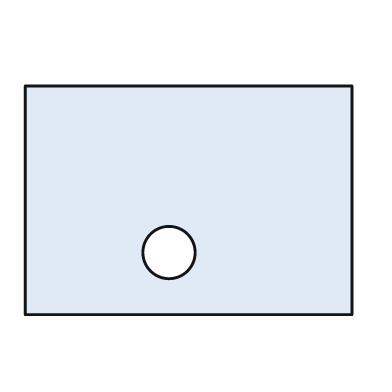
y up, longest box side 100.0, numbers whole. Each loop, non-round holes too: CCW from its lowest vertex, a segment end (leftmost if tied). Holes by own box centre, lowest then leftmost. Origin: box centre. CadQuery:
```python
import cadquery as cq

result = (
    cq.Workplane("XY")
    .moveTo(-50.0, -35.0)
    .lineTo(50.0, -35.0)
    .lineTo(50.0, 35.0)
    .lineTo(-50.0, 35.0)
    .close()
    .moveTo(-6.0, -16.0)
    .circle(8.0)
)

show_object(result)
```